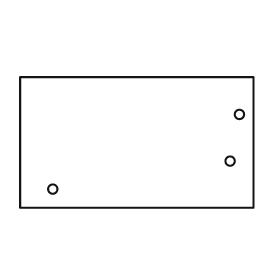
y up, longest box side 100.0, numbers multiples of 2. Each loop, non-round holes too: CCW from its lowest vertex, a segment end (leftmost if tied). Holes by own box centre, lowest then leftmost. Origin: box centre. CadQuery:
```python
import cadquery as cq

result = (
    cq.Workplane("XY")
    .moveTo(-50.0, -28.0)
    .lineTo(50.0, -28.0)
    .lineTo(50.0, 28.0)
    .lineTo(-50.0, 28.0)
    .close()
    .moveTo(-36.0, -20.0)
    .circle(2.0)
    .moveTo(40.0, -8.0)
    .circle(2.0)
    .moveTo(44.0, 12.0)
    .circle(2.0)
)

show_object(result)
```